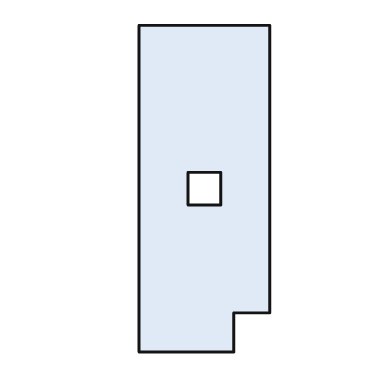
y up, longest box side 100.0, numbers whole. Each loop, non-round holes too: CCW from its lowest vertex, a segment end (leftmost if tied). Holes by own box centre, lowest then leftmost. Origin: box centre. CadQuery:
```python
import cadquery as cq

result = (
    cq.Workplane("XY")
    .moveTo(-20.0, -50.0)
    .lineTo(9.0, -50.0)
    .lineTo(9.0, -38.0)
    .lineTo(20.0, -38.0)
    .lineTo(20.0, 50.0)
    .lineTo(-20.0, 50.0)
    .close()
    .moveTo(-5.0, -5.0)
    .lineTo(5.0, -5.0)
    .lineTo(5.0, 5.0)
    .lineTo(-5.0, 5.0)
    .close()
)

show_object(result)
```